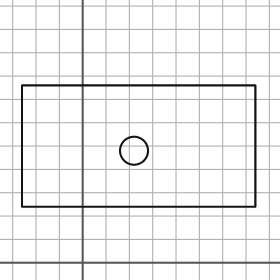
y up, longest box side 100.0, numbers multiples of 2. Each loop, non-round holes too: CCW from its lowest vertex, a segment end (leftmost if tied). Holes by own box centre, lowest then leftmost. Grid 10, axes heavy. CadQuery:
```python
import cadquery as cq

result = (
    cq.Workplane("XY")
    .moveTo(-26.0, 24.0)
    .lineTo(74.0, 24.0)
    .lineTo(74.0, 76.0)
    .lineTo(-26.0, 76.0)
    .close()
    .moveTo(22.0, 48.0)
    .circle(6.0)
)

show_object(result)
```